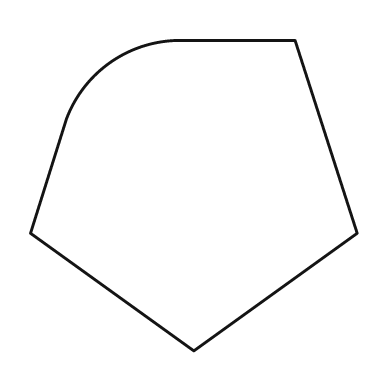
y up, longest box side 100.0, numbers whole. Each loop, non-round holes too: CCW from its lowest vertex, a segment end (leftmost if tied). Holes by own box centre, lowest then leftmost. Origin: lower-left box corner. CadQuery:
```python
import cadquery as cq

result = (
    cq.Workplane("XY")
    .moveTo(50.0, 0.0)
    .lineTo(100.0, 36.0)
    .lineTo(81.0, 95.0)
    .lineTo(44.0, 95.0)
    .threePointArc((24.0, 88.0), (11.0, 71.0))
    .lineTo(0.0, 36.0)
    .close()
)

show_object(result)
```